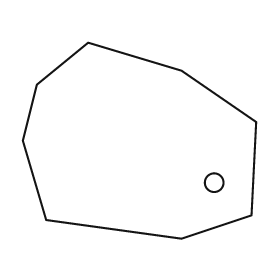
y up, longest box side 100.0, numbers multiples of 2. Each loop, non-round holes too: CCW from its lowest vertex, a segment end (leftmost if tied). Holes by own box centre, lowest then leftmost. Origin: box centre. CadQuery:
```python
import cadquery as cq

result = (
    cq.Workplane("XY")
    .moveTo(18.0, -42.0)
    .lineTo(48.0, -32.0)
    .lineTo(50.0, 8.0)
    .lineTo(18.0, 30.0)
    .lineTo(-22.0, 42.0)
    .lineTo(-44.0, 24.0)
    .lineTo(-50.0, 0.0)
    .lineTo(-40.0, -34.0)
    .close()
    .moveTo(32.0, -18.0)
    .circle(4.0)
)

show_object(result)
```